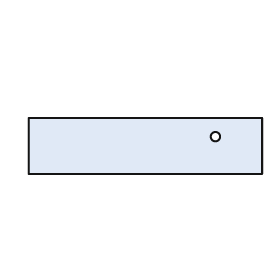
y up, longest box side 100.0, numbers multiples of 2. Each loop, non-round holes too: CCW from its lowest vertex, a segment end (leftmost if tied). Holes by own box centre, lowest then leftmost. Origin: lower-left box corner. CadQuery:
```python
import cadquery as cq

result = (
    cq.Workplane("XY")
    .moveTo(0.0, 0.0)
    .lineTo(100.0, 0.0)
    .lineTo(100.0, 24.0)
    .lineTo(0.0, 24.0)
    .close()
    .moveTo(80.0, 16.0)
    .circle(2.0)
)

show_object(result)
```